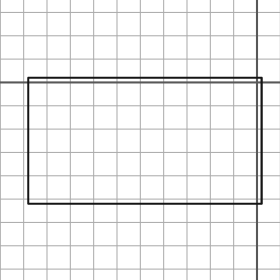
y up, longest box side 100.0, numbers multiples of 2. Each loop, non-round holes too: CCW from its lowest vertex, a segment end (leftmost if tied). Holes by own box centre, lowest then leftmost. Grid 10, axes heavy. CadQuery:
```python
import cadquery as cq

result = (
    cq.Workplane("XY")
    .moveTo(-98.0, -52.0)
    .lineTo(2.0, -52.0)
    .lineTo(2.0, 2.0)
    .lineTo(-98.0, 2.0)
    .close()
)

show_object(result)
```